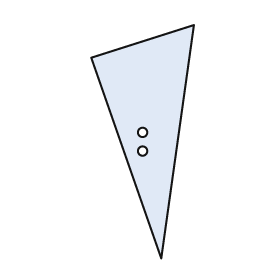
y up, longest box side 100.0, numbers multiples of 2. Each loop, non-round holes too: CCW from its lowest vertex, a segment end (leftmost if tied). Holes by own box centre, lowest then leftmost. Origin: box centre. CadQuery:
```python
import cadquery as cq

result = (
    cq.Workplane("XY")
    .moveTo(8.0, -50.0)
    .lineTo(22.0, 50.0)
    .lineTo(-22.0, 36.0)
    .close()
    .moveTo(0.0, -4.0)
    .circle(2.0)
    .moveTo(0.0, 4.0)
    .circle(2.0)
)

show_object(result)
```